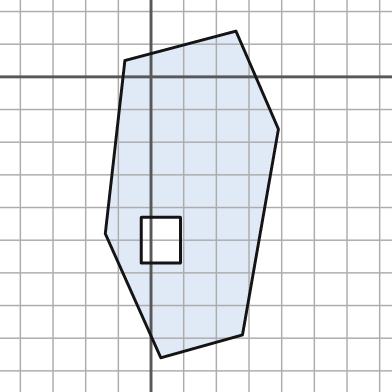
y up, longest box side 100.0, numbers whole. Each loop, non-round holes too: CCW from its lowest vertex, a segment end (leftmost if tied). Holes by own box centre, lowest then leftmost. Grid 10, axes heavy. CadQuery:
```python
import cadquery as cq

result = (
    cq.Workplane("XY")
    .moveTo(3.0, -86.0)
    .lineTo(28.0, -79.0)
    .lineTo(39.0, -16.0)
    .lineTo(26.0, 14.0)
    .lineTo(-8.0, 5.0)
    .lineTo(-14.0, -48.0)
    .close()
    .moveTo(-3.0, -57.0)
    .lineTo(9.0, -57.0)
    .lineTo(9.0, -43.0)
    .lineTo(-3.0, -43.0)
    .close()
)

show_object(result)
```